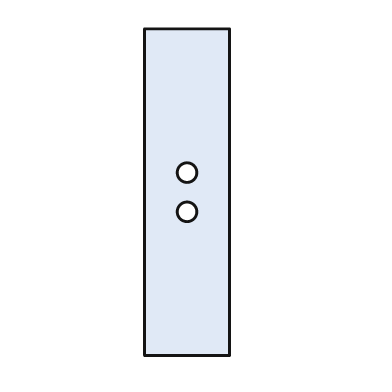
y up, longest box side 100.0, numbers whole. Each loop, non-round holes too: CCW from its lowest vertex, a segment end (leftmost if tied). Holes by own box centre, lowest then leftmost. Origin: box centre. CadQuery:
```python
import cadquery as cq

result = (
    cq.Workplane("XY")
    .moveTo(-13.0, -50.0)
    .lineTo(13.0, -50.0)
    .lineTo(13.0, 50.0)
    .lineTo(-13.0, 50.0)
    .close()
    .moveTo(0.0, -6.0)
    .circle(3.0)
    .moveTo(0.0, 6.0)
    .circle(3.0)
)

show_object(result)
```